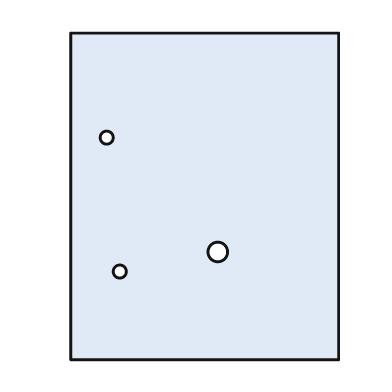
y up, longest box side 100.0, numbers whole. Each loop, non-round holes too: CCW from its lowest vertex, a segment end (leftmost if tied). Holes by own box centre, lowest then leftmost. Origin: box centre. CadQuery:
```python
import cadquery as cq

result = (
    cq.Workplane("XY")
    .moveTo(-41.0, -50.0)
    .lineTo(41.0, -50.0)
    .lineTo(41.0, 50.0)
    .lineTo(-41.0, 50.0)
    .close()
    .moveTo(-26.0, -23.0)
    .circle(2.0)
    .moveTo(4.0, -17.0)
    .circle(3.0)
    .moveTo(-30.0, 18.0)
    .circle(2.0)
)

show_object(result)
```